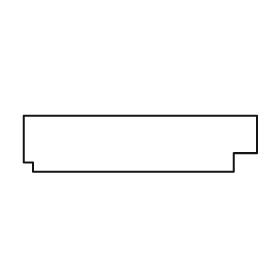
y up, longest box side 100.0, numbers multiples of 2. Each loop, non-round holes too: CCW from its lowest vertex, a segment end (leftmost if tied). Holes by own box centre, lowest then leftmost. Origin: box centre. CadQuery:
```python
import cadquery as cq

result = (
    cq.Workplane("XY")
    .moveTo(-46.0, -12.0)
    .lineTo(40.0, -12.0)
    .lineTo(40.0, -4.0)
    .lineTo(50.0, -4.0)
    .lineTo(50.0, 12.0)
    .lineTo(-50.0, 12.0)
    .lineTo(-50.0, -8.0)
    .lineTo(-46.0, -8.0)
    .close()
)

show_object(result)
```